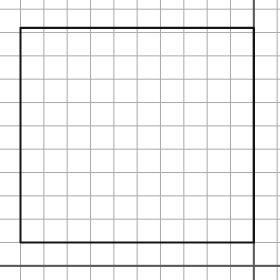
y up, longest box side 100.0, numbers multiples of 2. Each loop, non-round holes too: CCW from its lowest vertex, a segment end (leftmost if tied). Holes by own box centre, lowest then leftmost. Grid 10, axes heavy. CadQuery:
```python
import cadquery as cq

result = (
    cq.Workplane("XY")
    .moveTo(-100.0, 10.0)
    .lineTo(0.0, 10.0)
    .lineTo(0.0, 102.0)
    .lineTo(-100.0, 102.0)
    .close()
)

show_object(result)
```